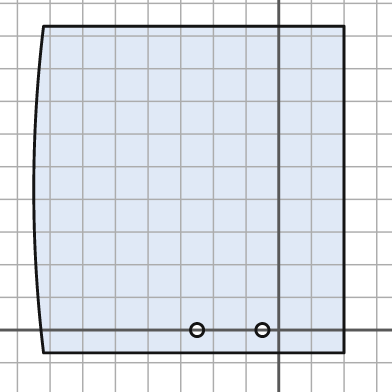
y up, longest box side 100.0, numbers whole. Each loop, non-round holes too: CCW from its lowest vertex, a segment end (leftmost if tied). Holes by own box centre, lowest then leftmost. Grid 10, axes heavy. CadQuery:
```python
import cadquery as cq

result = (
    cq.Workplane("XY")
    .moveTo(-72.0, -7.0)
    .lineTo(20.0, -7.0)
    .lineTo(20.0, 93.0)
    .lineTo(-72.0, 93.0)
    .threePointArc((-75.0, 43.0), (-72.0, -7.0))
    .close()
    .moveTo(-25.0, 0.0)
    .circle(2.0)
    .moveTo(-5.0, 0.0)
    .circle(2.0)
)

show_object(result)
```